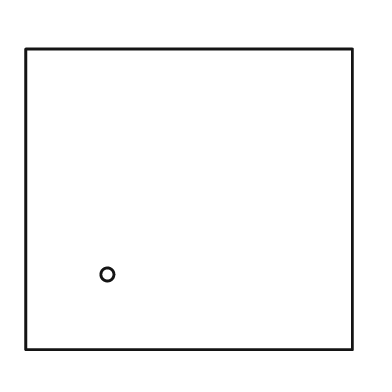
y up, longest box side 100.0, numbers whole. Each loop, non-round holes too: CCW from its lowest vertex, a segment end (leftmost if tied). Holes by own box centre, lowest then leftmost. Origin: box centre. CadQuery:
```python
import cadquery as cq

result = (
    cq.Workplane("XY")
    .moveTo(-50.0, -46.0)
    .lineTo(50.0, -46.0)
    .lineTo(50.0, 46.0)
    .lineTo(-50.0, 46.0)
    .close()
    .moveTo(-25.0, -23.0)
    .circle(2.0)
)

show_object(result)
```